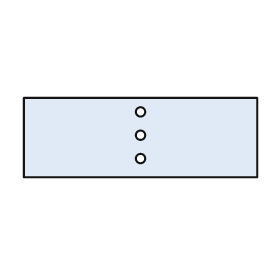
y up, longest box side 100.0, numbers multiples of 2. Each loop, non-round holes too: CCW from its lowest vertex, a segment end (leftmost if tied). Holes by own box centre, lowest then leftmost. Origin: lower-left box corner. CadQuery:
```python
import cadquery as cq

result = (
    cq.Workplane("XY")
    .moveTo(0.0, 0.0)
    .lineTo(100.0, 0.0)
    .lineTo(100.0, 34.0)
    .lineTo(0.0, 34.0)
    .close()
    .moveTo(50.0, 8.0)
    .circle(2.0)
    .moveTo(50.0, 18.0)
    .circle(2.0)
    .moveTo(50.0, 28.0)
    .circle(2.0)
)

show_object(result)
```